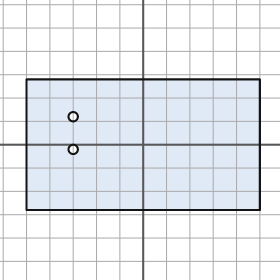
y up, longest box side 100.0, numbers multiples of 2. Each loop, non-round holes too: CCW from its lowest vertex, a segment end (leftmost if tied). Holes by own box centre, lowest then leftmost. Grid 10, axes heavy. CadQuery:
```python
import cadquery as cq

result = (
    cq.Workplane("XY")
    .moveTo(-50.0, -28.0)
    .lineTo(50.0, -28.0)
    .lineTo(50.0, 28.0)
    .lineTo(-50.0, 28.0)
    .close()
    .moveTo(-30.0, -2.0)
    .circle(2.0)
    .moveTo(-30.0, 12.0)
    .circle(2.0)
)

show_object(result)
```